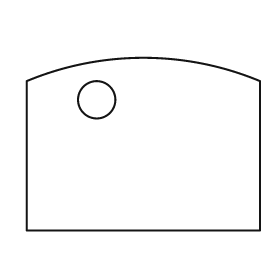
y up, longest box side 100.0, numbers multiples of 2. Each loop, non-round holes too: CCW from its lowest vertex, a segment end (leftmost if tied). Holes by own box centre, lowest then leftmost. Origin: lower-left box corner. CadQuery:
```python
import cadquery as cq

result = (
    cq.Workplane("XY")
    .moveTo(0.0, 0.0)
    .lineTo(100.0, 0.0)
    .lineTo(100.0, 64.0)
    .threePointArc((50.0, 74.0), (0.0, 64.0))
    .close()
    .moveTo(30.0, 56.0)
    .circle(8.0)
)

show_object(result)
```